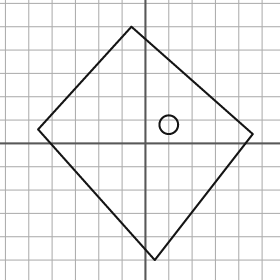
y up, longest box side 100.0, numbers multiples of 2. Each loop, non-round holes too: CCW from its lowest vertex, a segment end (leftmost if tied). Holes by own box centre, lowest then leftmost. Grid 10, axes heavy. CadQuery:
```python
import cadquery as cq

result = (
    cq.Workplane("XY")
    .moveTo(4.0, -50.0)
    .lineTo(46.0, 4.0)
    .lineTo(-6.0, 50.0)
    .lineTo(-46.0, 6.0)
    .close()
    .moveTo(10.0, 8.0)
    .circle(4.0)
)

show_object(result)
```